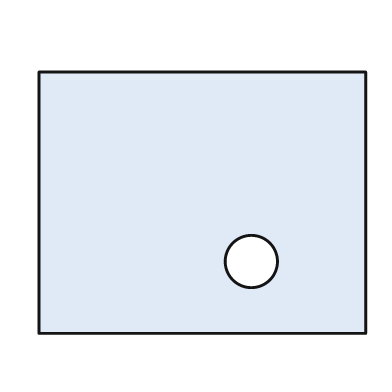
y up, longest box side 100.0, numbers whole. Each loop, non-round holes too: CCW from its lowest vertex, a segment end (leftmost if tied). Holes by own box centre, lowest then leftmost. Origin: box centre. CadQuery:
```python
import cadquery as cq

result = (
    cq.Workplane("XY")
    .moveTo(-50.0, -40.0)
    .lineTo(50.0, -40.0)
    .lineTo(50.0, 40.0)
    .lineTo(-50.0, 40.0)
    .close()
    .moveTo(15.0, -18.0)
    .circle(8.0)
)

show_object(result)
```